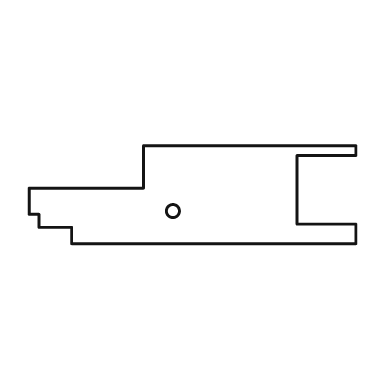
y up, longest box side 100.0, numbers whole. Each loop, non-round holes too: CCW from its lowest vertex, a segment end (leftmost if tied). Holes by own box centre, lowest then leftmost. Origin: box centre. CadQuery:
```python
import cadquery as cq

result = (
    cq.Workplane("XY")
    .moveTo(-37.0, -15.0)
    .lineTo(50.0, -15.0)
    .lineTo(50.0, -9.0)
    .lineTo(32.0, -9.0)
    .lineTo(32.0, 12.0)
    .lineTo(50.0, 12.0)
    .lineTo(50.0, 15.0)
    .lineTo(-15.0, 15.0)
    .lineTo(-15.0, 2.0)
    .lineTo(-50.0, 2.0)
    .lineTo(-50.0, -6.0)
    .lineTo(-47.0, -6.0)
    .lineTo(-47.0, -10.0)
    .lineTo(-37.0, -10.0)
    .close()
    .moveTo(-6.0, -5.0)
    .circle(2.0)
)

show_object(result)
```